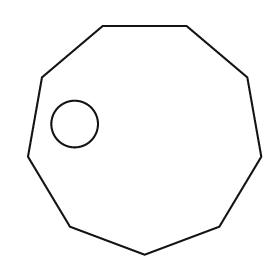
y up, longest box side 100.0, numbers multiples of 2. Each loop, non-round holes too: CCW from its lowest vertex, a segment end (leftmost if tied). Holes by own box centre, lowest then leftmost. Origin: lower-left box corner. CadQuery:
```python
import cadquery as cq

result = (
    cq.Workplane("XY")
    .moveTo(50.0, 0.0)
    .lineTo(82.0, 12.0)
    .lineTo(100.0, 42.0)
    .lineTo(94.0, 76.0)
    .lineTo(68.0, 98.0)
    .lineTo(32.0, 98.0)
    .lineTo(6.0, 76.0)
    .lineTo(0.0, 42.0)
    .lineTo(18.0, 12.0)
    .close()
    .moveTo(20.0, 56.0)
    .circle(10.0)
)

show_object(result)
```